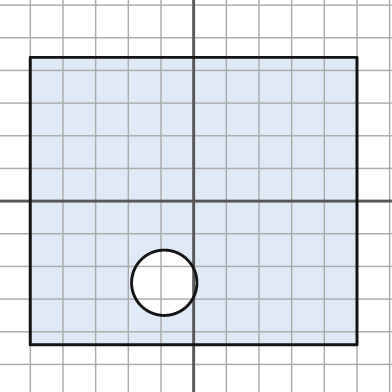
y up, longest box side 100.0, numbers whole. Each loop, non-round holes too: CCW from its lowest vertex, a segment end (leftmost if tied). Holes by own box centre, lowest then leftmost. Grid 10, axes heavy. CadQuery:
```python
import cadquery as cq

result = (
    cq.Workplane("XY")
    .moveTo(-50.0, -44.0)
    .lineTo(50.0, -44.0)
    .lineTo(50.0, 44.0)
    .lineTo(-50.0, 44.0)
    .close()
    .moveTo(-9.0, -25.0)
    .circle(10.0)
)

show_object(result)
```